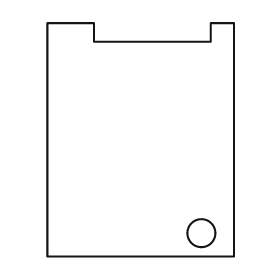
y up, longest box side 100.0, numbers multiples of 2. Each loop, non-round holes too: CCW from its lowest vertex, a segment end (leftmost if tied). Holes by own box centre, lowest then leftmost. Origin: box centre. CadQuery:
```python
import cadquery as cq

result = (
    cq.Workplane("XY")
    .moveTo(-40.0, -50.0)
    .lineTo(40.0, -50.0)
    .lineTo(40.0, 50.0)
    .lineTo(30.0, 50.0)
    .lineTo(30.0, 42.0)
    .lineTo(-20.0, 42.0)
    .lineTo(-20.0, 50.0)
    .lineTo(-40.0, 50.0)
    .close()
    .moveTo(26.0, -40.0)
    .circle(6.0)
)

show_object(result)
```